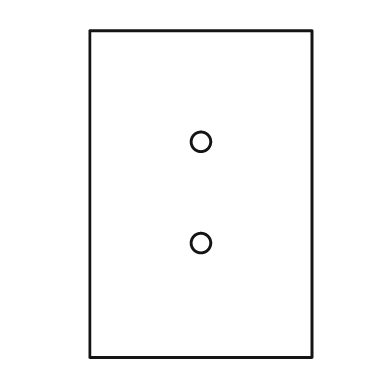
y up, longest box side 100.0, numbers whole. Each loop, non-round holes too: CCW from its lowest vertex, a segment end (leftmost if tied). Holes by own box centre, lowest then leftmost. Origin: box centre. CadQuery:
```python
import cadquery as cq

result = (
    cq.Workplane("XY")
    .moveTo(-34.0, -50.0)
    .lineTo(34.0, -50.0)
    .lineTo(34.0, 50.0)
    .lineTo(-34.0, 50.0)
    .close()
    .moveTo(0.0, -15.0)
    .circle(3.0)
    .moveTo(0.0, 16.0)
    .circle(3.0)
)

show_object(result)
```